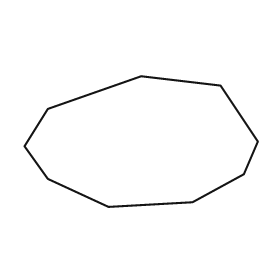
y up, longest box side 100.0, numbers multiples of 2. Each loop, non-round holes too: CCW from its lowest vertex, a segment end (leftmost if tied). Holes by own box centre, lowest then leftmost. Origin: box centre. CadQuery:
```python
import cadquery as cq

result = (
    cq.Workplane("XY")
    .moveTo(-14.0, -28.0)
    .lineTo(22.0, -26.0)
    .lineTo(44.0, -14.0)
    .lineTo(50.0, 0.0)
    .lineTo(34.0, 24.0)
    .lineTo(0.0, 28.0)
    .lineTo(-40.0, 14.0)
    .lineTo(-50.0, -2.0)
    .lineTo(-40.0, -16.0)
    .close()
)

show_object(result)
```